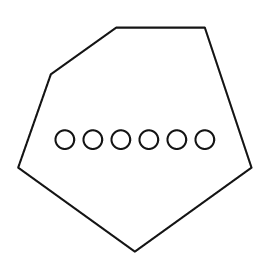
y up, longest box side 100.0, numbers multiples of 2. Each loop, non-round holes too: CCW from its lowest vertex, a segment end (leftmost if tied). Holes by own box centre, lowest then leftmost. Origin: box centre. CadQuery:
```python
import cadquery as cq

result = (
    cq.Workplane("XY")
    .moveTo(0.0, -48.0)
    .lineTo(50.0, -12.0)
    .lineTo(30.0, 48.0)
    .lineTo(-8.0, 48.0)
    .lineTo(-36.0, 28.0)
    .lineTo(-50.0, -12.0)
    .close()
    .moveTo(-30.0, 0.0)
    .circle(4.0)
    .moveTo(-18.0, 0.0)
    .circle(4.0)
    .moveTo(-6.0, 0.0)
    .circle(4.0)
    .moveTo(6.0, 0.0)
    .circle(4.0)
    .moveTo(18.0, 0.0)
    .circle(4.0)
    .moveTo(30.0, 0.0)
    .circle(4.0)
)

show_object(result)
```